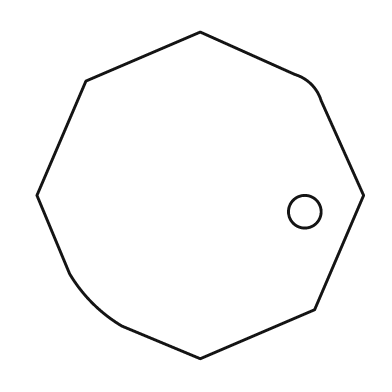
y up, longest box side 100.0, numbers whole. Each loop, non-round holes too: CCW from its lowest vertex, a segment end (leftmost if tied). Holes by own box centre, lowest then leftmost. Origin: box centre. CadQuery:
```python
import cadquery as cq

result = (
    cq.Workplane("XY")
    .moveTo(0.0, -50.0)
    .lineTo(35.0, -35.0)
    .lineTo(50.0, 0.0)
    .lineTo(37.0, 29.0)
    .threePointArc((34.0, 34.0), (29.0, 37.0))
    .lineTo(0.0, 50.0)
    .lineTo(-35.0, 35.0)
    .lineTo(-50.0, 0.0)
    .lineTo(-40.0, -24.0)
    .threePointArc((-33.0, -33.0), (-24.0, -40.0))
    .close()
    .moveTo(32.0, -5.0)
    .circle(5.0)
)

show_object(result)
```